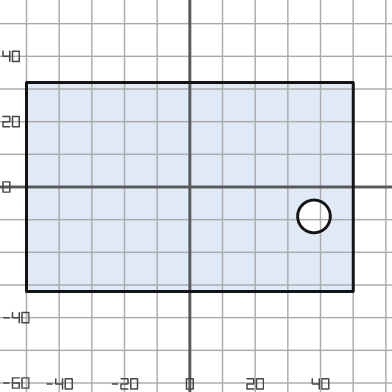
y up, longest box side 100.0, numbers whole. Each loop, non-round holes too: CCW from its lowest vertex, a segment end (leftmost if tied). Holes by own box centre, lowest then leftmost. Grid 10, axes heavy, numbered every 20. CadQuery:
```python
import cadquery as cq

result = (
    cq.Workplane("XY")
    .moveTo(-50.0, -32.0)
    .lineTo(50.0, -32.0)
    .lineTo(50.0, 32.0)
    .lineTo(-50.0, 32.0)
    .close()
    .moveTo(38.0, -9.0)
    .circle(5.0)
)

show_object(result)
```